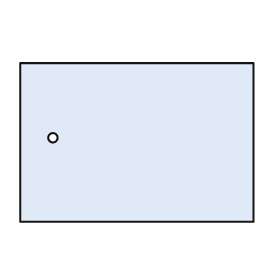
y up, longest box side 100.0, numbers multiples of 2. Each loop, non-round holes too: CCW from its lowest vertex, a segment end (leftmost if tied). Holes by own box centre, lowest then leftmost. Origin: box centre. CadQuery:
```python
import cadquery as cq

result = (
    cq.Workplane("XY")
    .moveTo(-50.0, -34.0)
    .lineTo(50.0, -34.0)
    .lineTo(50.0, 34.0)
    .lineTo(-50.0, 34.0)
    .close()
    .moveTo(-36.0, 2.0)
    .circle(2.0)
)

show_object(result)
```